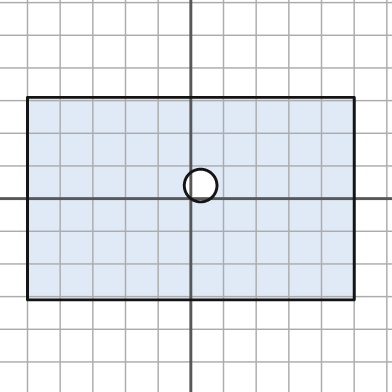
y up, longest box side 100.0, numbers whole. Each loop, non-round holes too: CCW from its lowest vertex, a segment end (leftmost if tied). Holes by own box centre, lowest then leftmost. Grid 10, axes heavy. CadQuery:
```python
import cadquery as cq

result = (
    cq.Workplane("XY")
    .moveTo(-50.0, -31.0)
    .lineTo(50.0, -31.0)
    .lineTo(50.0, 31.0)
    .lineTo(-50.0, 31.0)
    .close()
    .moveTo(3.0, 4.0)
    .circle(5.0)
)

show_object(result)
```